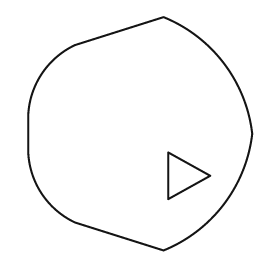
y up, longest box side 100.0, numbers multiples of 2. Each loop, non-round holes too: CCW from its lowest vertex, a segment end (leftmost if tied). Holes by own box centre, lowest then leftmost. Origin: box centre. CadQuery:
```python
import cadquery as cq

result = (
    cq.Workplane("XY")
    .moveTo(10.0, -50.0)
    .threePointArc((36.0, -30.0), (48.0, 0.0))
    .threePointArc((36.0, 30.0), (10.0, 50.0))
    .lineTo(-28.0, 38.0)
    .threePointArc((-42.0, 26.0), (-48.0, 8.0))
    .lineTo(-48.0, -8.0)
    .threePointArc((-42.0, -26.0), (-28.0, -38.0))
    .close()
    .moveTo(12.0, -28.0)
    .lineTo(30.0, -18.0)
    .lineTo(12.0, -8.0)
    .close()
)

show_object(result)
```